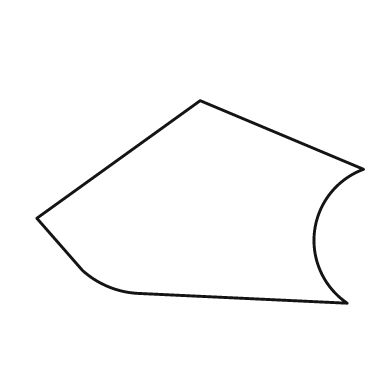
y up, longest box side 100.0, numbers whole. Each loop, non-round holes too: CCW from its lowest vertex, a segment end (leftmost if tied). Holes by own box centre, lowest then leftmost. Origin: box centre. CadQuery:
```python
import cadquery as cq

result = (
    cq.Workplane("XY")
    .moveTo(45.0, -31.0)
    .threePointArc((35.0, -9.0), (50.0, 10.0))
    .lineTo(0.0, 31.0)
    .lineTo(-50.0, -5.0)
    .lineTo(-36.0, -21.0)
    .threePointArc((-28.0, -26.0), (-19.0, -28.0))
    .close()
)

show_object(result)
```